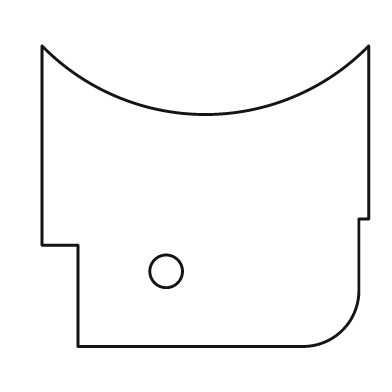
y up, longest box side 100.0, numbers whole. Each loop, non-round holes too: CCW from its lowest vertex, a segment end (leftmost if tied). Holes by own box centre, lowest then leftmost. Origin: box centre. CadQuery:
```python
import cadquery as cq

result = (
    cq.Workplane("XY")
    .moveTo(-39.0, -46.0)
    .lineTo(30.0, -46.0)
    .threePointArc((42.0, -41.0), (47.0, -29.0))
    .lineTo(47.0, -7.0)
    .lineTo(50.0, -7.0)
    .lineTo(50.0, 46.0)
    .threePointArc((0.0, 25.0), (-50.0, 46.0))
    .lineTo(-50.0, -15.0)
    .lineTo(-39.0, -15.0)
    .close()
    .moveTo(-12.0, -23.0)
    .circle(5.0)
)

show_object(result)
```